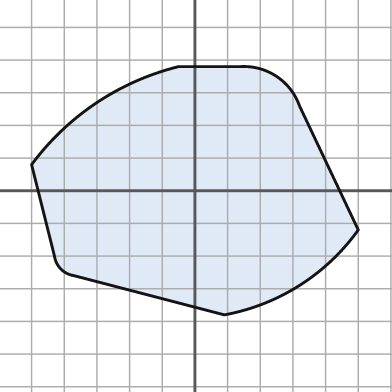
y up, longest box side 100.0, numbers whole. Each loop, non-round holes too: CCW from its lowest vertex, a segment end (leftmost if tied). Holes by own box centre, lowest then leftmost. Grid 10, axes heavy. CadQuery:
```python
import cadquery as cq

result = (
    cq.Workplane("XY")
    .moveTo(9.0, -38.0)
    .threePointArc((32.0, -29.0), (50.0, -12.0))
    .lineTo(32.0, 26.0)
    .threePointArc((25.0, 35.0), (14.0, 38.0))
    .lineTo(-5.0, 38.0)
    .threePointArc((-30.0, 27.0), (-50.0, 8.0))
    .lineTo(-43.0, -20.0)
    .threePointArc((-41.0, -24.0), (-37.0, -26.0))
    .close()
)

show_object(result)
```